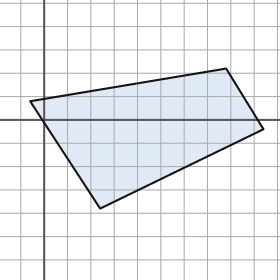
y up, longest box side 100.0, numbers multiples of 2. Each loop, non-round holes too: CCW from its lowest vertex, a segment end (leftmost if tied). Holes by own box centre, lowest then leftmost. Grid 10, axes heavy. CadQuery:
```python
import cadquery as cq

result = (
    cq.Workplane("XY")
    .moveTo(24.0, -38.0)
    .lineTo(94.0, -4.0)
    .lineTo(78.0, 22.0)
    .lineTo(-6.0, 8.0)
    .close()
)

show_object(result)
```